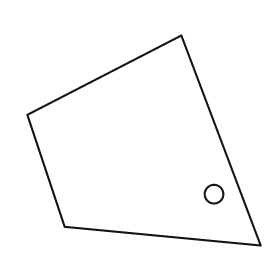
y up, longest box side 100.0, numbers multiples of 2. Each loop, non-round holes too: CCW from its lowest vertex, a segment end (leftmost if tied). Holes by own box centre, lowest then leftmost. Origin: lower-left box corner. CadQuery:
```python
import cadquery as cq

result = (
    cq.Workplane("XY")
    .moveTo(100.0, 0.0)
    .lineTo(66.0, 90.0)
    .lineTo(0.0, 56.0)
    .lineTo(16.0, 8.0)
    .close()
    .moveTo(80.0, 22.0)
    .circle(4.0)
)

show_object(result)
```